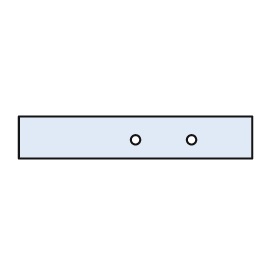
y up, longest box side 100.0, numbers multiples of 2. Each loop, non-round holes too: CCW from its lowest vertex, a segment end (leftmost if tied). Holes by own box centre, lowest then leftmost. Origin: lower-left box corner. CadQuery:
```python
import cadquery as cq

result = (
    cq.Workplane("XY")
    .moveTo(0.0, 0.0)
    .lineTo(100.0, 0.0)
    .lineTo(100.0, 18.0)
    .lineTo(0.0, 18.0)
    .close()
    .moveTo(50.0, 8.0)
    .circle(2.0)
    .moveTo(74.0, 8.0)
    .circle(2.0)
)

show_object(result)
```